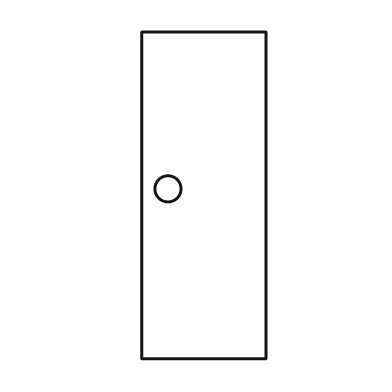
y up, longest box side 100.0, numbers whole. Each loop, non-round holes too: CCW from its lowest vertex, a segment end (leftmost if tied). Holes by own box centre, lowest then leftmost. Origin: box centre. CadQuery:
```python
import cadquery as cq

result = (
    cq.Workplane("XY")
    .moveTo(-19.0, -50.0)
    .lineTo(19.0, -50.0)
    .lineTo(19.0, 50.0)
    .lineTo(-19.0, 50.0)
    .close()
    .moveTo(-11.0, 2.0)
    .circle(4.0)
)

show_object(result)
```